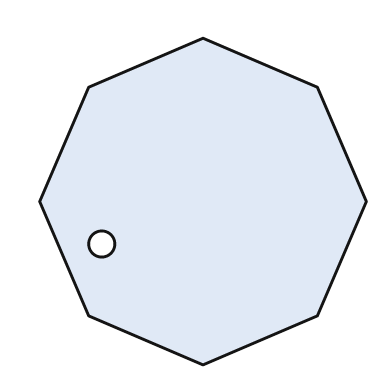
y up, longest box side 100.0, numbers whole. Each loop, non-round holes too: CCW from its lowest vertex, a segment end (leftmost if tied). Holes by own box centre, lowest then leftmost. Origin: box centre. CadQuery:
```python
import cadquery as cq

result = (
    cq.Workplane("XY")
    .moveTo(0.0, -50.0)
    .lineTo(35.0, -35.0)
    .lineTo(50.0, 0.0)
    .lineTo(35.0, 35.0)
    .lineTo(0.0, 50.0)
    .lineTo(-35.0, 35.0)
    .lineTo(-50.0, 0.0)
    .lineTo(-35.0, -35.0)
    .close()
    .moveTo(-31.0, -13.0)
    .circle(4.0)
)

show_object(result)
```